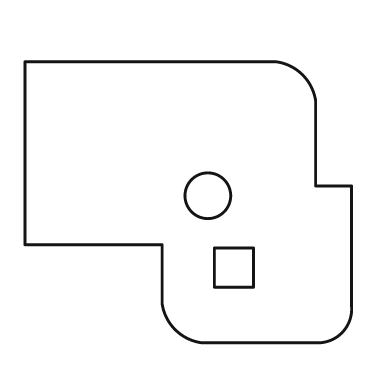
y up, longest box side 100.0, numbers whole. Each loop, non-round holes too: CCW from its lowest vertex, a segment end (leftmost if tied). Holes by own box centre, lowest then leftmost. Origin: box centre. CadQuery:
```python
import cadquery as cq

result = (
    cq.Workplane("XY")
    .moveTo(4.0, -43.0)
    .lineTo(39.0, -43.0)
    .threePointArc((47.0, -40.0), (50.0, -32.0))
    .lineTo(50.0, 5.0)
    .lineTo(39.0, 5.0)
    .lineTo(39.0, 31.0)
    .threePointArc((35.0, 39.0), (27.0, 43.0))
    .lineTo(-50.0, 43.0)
    .lineTo(-50.0, -13.0)
    .lineTo(-8.0, -13.0)
    .lineTo(-8.0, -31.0)
    .threePointArc((-4.0, -39.0), (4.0, -43.0))
    .close()
    .moveTo(8.0, -26.0)
    .lineTo(20.0, -26.0)
    .lineTo(20.0, -14.0)
    .lineTo(8.0, -14.0)
    .close()
    .moveTo(6.0, 2.0)
    .circle(7.0)
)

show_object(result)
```